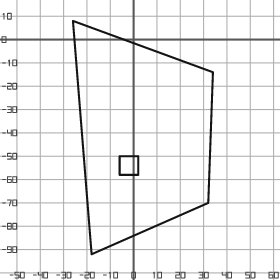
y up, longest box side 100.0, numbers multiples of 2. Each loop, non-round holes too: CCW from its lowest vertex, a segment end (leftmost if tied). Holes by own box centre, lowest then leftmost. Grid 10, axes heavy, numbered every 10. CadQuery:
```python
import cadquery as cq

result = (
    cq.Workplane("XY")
    .moveTo(-18.0, -92.0)
    .lineTo(32.0, -70.0)
    .lineTo(34.0, -14.0)
    .lineTo(-26.0, 8.0)
    .close()
    .moveTo(-6.0, -58.0)
    .lineTo(2.0, -58.0)
    .lineTo(2.0, -50.0)
    .lineTo(-6.0, -50.0)
    .close()
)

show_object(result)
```